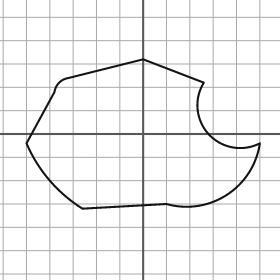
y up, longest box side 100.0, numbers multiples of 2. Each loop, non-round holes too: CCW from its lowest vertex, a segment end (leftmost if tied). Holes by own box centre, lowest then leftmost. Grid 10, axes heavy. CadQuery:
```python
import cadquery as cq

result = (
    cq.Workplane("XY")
    .moveTo(-26.0, -32.0)
    .lineTo(10.0, -30.0)
    .threePointArc((36.0, -26.0), (50.0, -4.0))
    .threePointArc((28.0, 0.0), (26.0, 22.0))
    .lineTo(0.0, 32.0)
    .lineTo(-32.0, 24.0)
    .threePointArc((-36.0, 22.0), (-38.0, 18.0))
    .lineTo(-50.0, -4.0)
    .threePointArc((-40.0, -20.0), (-26.0, -32.0))
    .close()
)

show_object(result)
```